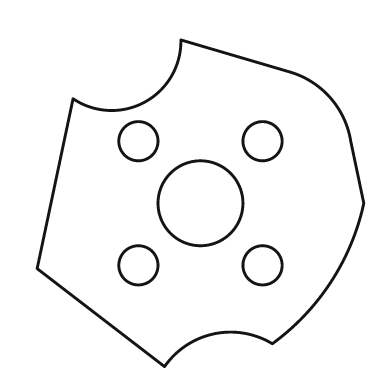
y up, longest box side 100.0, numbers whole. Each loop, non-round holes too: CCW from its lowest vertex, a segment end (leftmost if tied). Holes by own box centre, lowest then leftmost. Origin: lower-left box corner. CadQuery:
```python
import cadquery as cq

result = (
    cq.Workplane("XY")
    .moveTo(39.0, 0.0)
    .threePointArc((54.0, 10.0), (72.0, 7.0))
    .threePointArc((90.0, 26.0), (100.0, 50.0))
    .lineTo(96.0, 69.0)
    .threePointArc((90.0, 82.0), (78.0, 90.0))
    .lineTo(44.0, 100.0)
    .threePointArc((33.0, 81.0), (11.0, 82.0))
    .lineTo(0.0, 30.0)
    .close()
    .moveTo(31.0, 31.0)
    .circle(6.0)
    .moveTo(69.0, 31.0)
    .circle(6.0)
    .moveTo(50.0, 50.0)
    .circle(13.0)
    .moveTo(31.0, 69.0)
    .circle(6.0)
    .moveTo(69.0, 69.0)
    .circle(6.0)
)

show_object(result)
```